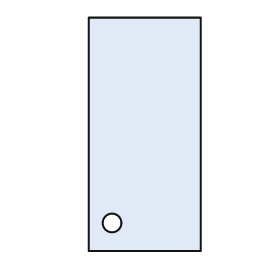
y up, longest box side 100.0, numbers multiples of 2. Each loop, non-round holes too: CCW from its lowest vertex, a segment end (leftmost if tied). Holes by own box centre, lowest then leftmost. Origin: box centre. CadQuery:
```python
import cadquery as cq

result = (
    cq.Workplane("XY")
    .moveTo(-24.0, -50.0)
    .lineTo(24.0, -50.0)
    .lineTo(24.0, 50.0)
    .lineTo(-24.0, 50.0)
    .close()
    .moveTo(-14.0, -38.0)
    .circle(4.0)
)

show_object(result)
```